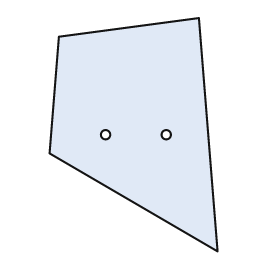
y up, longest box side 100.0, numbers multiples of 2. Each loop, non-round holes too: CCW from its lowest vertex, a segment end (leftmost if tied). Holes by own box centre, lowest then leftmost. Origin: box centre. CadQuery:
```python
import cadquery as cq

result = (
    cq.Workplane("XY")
    .moveTo(36.0, -50.0)
    .lineTo(28.0, 50.0)
    .lineTo(-32.0, 42.0)
    .lineTo(-36.0, -8.0)
    .close()
    .moveTo(-12.0, 0.0)
    .circle(2.0)
    .moveTo(14.0, 0.0)
    .circle(2.0)
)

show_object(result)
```